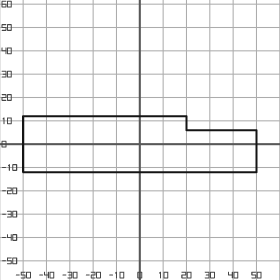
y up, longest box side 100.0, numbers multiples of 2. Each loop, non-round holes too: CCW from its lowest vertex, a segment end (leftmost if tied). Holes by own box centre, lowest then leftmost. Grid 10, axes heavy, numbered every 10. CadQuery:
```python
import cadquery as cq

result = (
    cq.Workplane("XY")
    .moveTo(-50.0, -12.0)
    .lineTo(50.0, -12.0)
    .lineTo(50.0, 6.0)
    .lineTo(20.0, 6.0)
    .lineTo(20.0, 12.0)
    .lineTo(-50.0, 12.0)
    .close()
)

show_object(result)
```